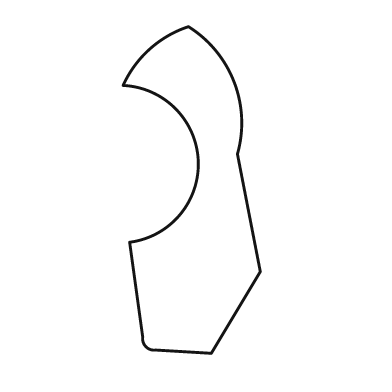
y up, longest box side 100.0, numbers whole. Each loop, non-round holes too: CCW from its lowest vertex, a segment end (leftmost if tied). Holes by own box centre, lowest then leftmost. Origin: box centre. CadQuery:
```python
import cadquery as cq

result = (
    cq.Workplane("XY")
    .moveTo(6.0, -50.0)
    .lineTo(21.0, -25.0)
    .lineTo(14.0, 11.0)
    .threePointArc((13.0, 33.0), (-1.0, 50.0))
    .threePointArc((-13.0, 43.0), (-21.0, 32.0))
    .threePointArc((2.0, 9.0), (-19.0, -16.0))
    .lineTo(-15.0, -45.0)
    .threePointArc((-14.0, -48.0), (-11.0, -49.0))
    .close()
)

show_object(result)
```